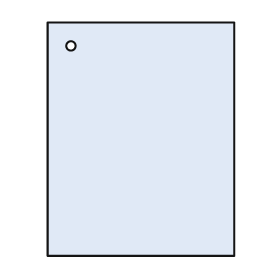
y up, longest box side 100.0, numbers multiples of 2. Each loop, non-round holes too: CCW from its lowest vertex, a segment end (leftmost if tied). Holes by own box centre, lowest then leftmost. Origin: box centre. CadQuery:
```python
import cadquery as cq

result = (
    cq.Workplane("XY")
    .moveTo(-40.0, -50.0)
    .lineTo(40.0, -50.0)
    .lineTo(40.0, 50.0)
    .lineTo(-40.0, 50.0)
    .close()
    .moveTo(-30.0, 40.0)
    .circle(2.0)
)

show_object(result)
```